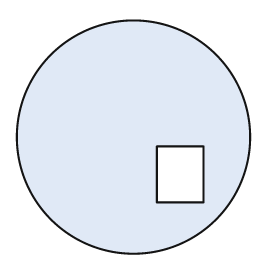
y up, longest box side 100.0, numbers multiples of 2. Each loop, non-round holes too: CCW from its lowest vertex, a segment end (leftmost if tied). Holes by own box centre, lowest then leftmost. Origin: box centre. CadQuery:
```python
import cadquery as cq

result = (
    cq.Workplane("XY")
    .moveTo(0.0, 0.0)
    .circle(50.0)
    .moveTo(10.0, -28.0)
    .lineTo(30.0, -28.0)
    .lineTo(30.0, -4.0)
    .lineTo(10.0, -4.0)
    .close()
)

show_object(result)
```